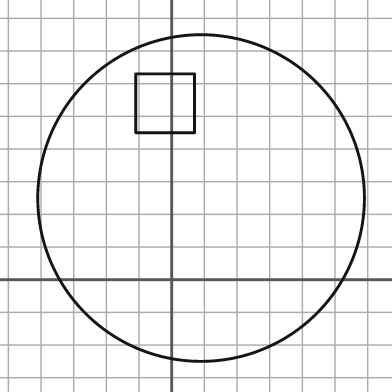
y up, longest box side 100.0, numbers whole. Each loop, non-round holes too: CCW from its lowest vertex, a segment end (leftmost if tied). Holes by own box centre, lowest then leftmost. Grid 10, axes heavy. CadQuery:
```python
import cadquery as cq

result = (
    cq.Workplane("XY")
    .moveTo(9.0, 25.0)
    .circle(50.0)
    .moveTo(-11.0, 45.0)
    .lineTo(7.0, 45.0)
    .lineTo(7.0, 63.0)
    .lineTo(-11.0, 63.0)
    .close()
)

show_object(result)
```